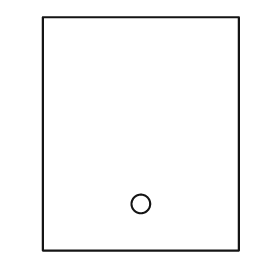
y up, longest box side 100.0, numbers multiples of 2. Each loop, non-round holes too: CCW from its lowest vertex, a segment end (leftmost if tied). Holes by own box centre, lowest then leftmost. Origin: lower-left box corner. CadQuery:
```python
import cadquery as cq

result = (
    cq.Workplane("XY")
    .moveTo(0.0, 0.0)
    .lineTo(84.0, 0.0)
    .lineTo(84.0, 100.0)
    .lineTo(0.0, 100.0)
    .close()
    .moveTo(42.0, 20.0)
    .circle(4.0)
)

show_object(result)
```